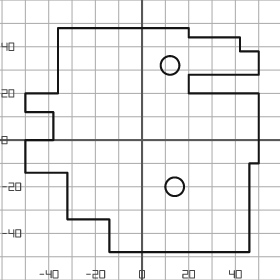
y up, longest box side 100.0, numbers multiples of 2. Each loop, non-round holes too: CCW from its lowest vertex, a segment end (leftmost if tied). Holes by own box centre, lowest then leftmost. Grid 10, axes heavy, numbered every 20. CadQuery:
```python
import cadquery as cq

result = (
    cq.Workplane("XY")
    .moveTo(-14.0, -48.0)
    .lineTo(46.0, -48.0)
    .lineTo(46.0, -10.0)
    .lineTo(50.0, -10.0)
    .lineTo(50.0, 20.0)
    .lineTo(20.0, 20.0)
    .lineTo(20.0, 28.0)
    .lineTo(50.0, 28.0)
    .lineTo(50.0, 38.0)
    .lineTo(42.0, 38.0)
    .lineTo(42.0, 44.0)
    .lineTo(20.0, 44.0)
    .lineTo(20.0, 48.0)
    .lineTo(-36.0, 48.0)
    .lineTo(-36.0, 20.0)
    .lineTo(-50.0, 20.0)
    .lineTo(-50.0, 12.0)
    .lineTo(-38.0, 12.0)
    .lineTo(-38.0, 0.0)
    .lineTo(-50.0, 0.0)
    .lineTo(-50.0, -14.0)
    .lineTo(-32.0, -14.0)
    .lineTo(-32.0, -34.0)
    .lineTo(-14.0, -34.0)
    .close()
    .moveTo(14.0, -20.0)
    .circle(4.0)
    .moveTo(12.0, 32.0)
    .circle(4.0)
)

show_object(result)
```